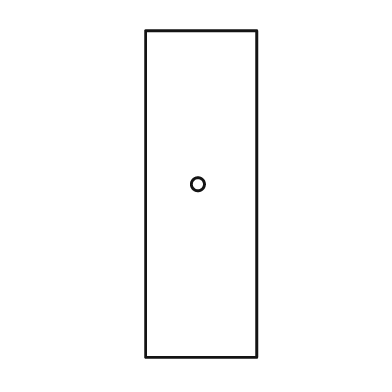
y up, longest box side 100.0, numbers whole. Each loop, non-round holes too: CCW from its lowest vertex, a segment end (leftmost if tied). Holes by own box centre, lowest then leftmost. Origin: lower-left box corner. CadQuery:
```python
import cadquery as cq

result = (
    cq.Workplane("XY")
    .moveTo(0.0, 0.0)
    .lineTo(34.0, 0.0)
    .lineTo(34.0, 100.0)
    .lineTo(0.0, 100.0)
    .close()
    .moveTo(16.0, 53.0)
    .circle(2.0)
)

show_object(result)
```